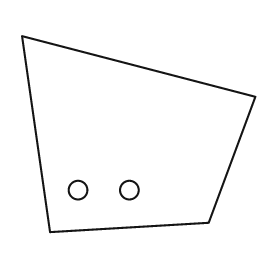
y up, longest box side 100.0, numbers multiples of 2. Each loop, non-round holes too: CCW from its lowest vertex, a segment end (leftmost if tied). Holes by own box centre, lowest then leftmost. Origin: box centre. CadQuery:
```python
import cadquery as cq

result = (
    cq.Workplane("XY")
    .moveTo(-38.0, -42.0)
    .lineTo(30.0, -38.0)
    .lineTo(50.0, 16.0)
    .lineTo(-50.0, 42.0)
    .close()
    .moveTo(-26.0, -24.0)
    .circle(4.0)
    .moveTo(-4.0, -24.0)
    .circle(4.0)
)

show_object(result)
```